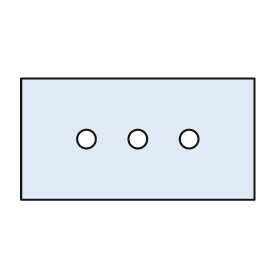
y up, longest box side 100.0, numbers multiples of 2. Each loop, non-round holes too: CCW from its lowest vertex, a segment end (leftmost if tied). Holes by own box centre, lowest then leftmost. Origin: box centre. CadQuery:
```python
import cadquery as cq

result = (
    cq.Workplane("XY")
    .moveTo(-50.0, -26.0)
    .lineTo(50.0, -26.0)
    .lineTo(50.0, 26.0)
    .lineTo(-50.0, 26.0)
    .close()
    .moveTo(-22.0, 0.0)
    .circle(4.0)
    .moveTo(0.0, 0.0)
    .circle(4.0)
    .moveTo(22.0, 0.0)
    .circle(4.0)
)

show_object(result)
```